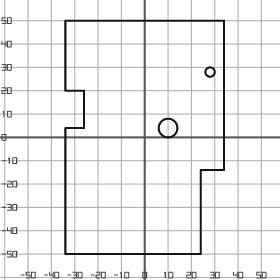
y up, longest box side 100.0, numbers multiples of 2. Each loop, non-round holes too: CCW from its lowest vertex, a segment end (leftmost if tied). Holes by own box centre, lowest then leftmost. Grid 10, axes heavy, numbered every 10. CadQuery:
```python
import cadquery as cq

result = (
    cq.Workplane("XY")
    .moveTo(-34.0, -50.0)
    .lineTo(24.0, -50.0)
    .lineTo(24.0, -14.0)
    .lineTo(34.0, -14.0)
    .lineTo(34.0, 50.0)
    .lineTo(-34.0, 50.0)
    .lineTo(-34.0, 20.0)
    .lineTo(-26.0, 20.0)
    .lineTo(-26.0, 4.0)
    .lineTo(-34.0, 4.0)
    .close()
    .moveTo(10.0, 4.0)
    .circle(4.0)
    .moveTo(28.0, 28.0)
    .circle(2.0)
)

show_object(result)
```